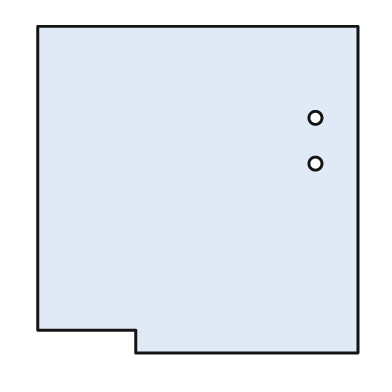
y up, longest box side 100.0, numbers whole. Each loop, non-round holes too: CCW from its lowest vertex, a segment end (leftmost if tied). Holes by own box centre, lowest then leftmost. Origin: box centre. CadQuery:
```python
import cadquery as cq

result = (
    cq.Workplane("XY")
    .moveTo(-19.0, -50.0)
    .lineTo(49.0, -50.0)
    .lineTo(49.0, 50.0)
    .lineTo(-49.0, 50.0)
    .lineTo(-49.0, -43.0)
    .lineTo(-19.0, -43.0)
    .close()
    .moveTo(36.0, 8.0)
    .circle(2.0)
    .moveTo(36.0, 22.0)
    .circle(2.0)
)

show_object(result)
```